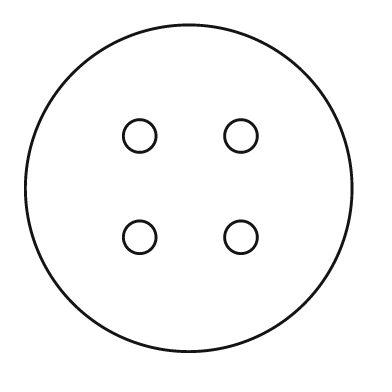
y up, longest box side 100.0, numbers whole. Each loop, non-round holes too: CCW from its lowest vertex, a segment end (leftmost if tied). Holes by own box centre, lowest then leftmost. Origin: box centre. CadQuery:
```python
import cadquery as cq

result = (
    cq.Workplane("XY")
    .moveTo(0.0, 0.0)
    .circle(50.0)
    .moveTo(-15.0, -15.0)
    .circle(5.0)
    .moveTo(16.0, -15.0)
    .circle(5.0)
    .moveTo(-15.0, 16.0)
    .circle(5.0)
    .moveTo(16.0, 16.0)
    .circle(5.0)
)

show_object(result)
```